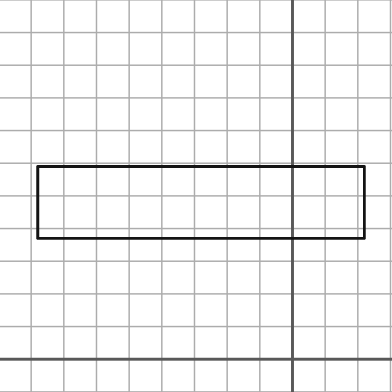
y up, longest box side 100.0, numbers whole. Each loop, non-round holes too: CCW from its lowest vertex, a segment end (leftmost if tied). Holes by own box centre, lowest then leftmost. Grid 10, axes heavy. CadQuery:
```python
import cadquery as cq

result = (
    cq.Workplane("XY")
    .moveTo(-78.0, 37.0)
    .lineTo(22.0, 37.0)
    .lineTo(22.0, 59.0)
    .lineTo(-78.0, 59.0)
    .close()
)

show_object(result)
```